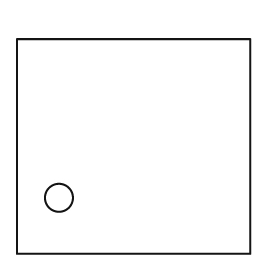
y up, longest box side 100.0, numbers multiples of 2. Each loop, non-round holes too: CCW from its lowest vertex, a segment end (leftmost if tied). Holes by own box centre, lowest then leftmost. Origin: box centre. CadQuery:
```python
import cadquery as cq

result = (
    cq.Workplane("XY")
    .moveTo(-50.0, -46.0)
    .lineTo(50.0, -46.0)
    .lineTo(50.0, 46.0)
    .lineTo(-50.0, 46.0)
    .close()
    .moveTo(-32.0, -22.0)
    .circle(6.0)
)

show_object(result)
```